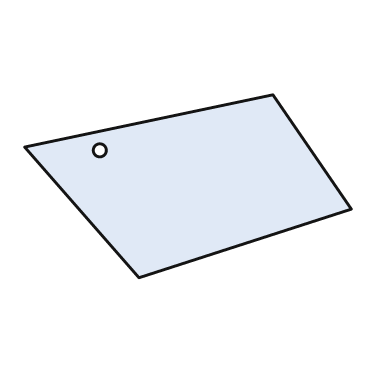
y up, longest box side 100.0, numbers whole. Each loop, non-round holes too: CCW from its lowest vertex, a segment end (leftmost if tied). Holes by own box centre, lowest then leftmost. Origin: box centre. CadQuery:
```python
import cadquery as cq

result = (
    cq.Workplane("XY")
    .moveTo(-15.0, -28.0)
    .lineTo(50.0, -7.0)
    .lineTo(26.0, 28.0)
    .lineTo(-50.0, 12.0)
    .close()
    .moveTo(-27.0, 11.0)
    .circle(2.0)
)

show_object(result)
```